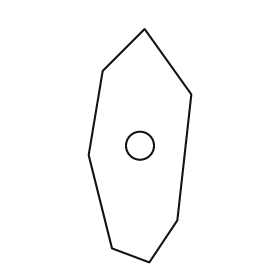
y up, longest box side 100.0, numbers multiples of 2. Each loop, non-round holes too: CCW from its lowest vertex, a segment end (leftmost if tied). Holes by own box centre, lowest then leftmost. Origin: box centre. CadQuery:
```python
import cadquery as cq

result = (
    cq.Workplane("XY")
    .moveTo(4.0, -50.0)
    .lineTo(16.0, -32.0)
    .lineTo(22.0, 22.0)
    .lineTo(2.0, 50.0)
    .lineTo(-16.0, 32.0)
    .lineTo(-22.0, -4.0)
    .lineTo(-12.0, -44.0)
    .close()
    .moveTo(0.0, 0.0)
    .circle(6.0)
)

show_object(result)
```